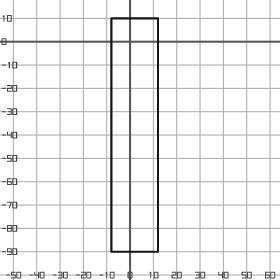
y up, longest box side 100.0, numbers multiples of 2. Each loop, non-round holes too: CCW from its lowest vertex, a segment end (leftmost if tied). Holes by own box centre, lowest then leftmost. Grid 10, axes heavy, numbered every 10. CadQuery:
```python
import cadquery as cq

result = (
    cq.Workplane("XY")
    .moveTo(-8.0, -90.0)
    .lineTo(12.0, -90.0)
    .lineTo(12.0, 10.0)
    .lineTo(-8.0, 10.0)
    .close()
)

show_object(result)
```